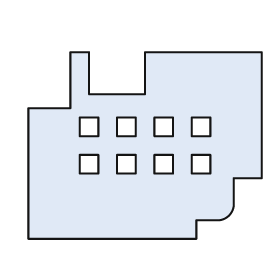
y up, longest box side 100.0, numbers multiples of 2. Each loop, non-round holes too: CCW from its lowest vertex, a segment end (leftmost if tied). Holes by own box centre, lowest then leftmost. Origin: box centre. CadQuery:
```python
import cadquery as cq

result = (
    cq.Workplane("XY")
    .moveTo(-50.0, -40.0)
    .lineTo(22.0, -40.0)
    .lineTo(22.0, -32.0)
    .lineTo(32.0, -32.0)
    .threePointArc((36.0, -30.0), (38.0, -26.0))
    .lineTo(38.0, -14.0)
    .lineTo(50.0, -14.0)
    .lineTo(50.0, 40.0)
    .lineTo(0.0, 40.0)
    .lineTo(0.0, 22.0)
    .lineTo(-24.0, 22.0)
    .lineTo(-24.0, 40.0)
    .lineTo(-32.0, 40.0)
    .lineTo(-32.0, 16.0)
    .lineTo(-50.0, 16.0)
    .close()
    .moveTo(-28.0, -12.0)
    .lineTo(-20.0, -12.0)
    .lineTo(-20.0, -4.0)
    .lineTo(-28.0, -4.0)
    .close()
    .moveTo(-12.0, -12.0)
    .lineTo(-4.0, -12.0)
    .lineTo(-4.0, -4.0)
    .lineTo(-12.0, -4.0)
    .close()
    .moveTo(4.0, -12.0)
    .lineTo(12.0, -12.0)
    .lineTo(12.0, -4.0)
    .lineTo(4.0, -4.0)
    .close()
    .moveTo(20.0, -12.0)
    .lineTo(28.0, -12.0)
    .lineTo(28.0, -4.0)
    .lineTo(20.0, -4.0)
    .close()
    .moveTo(-28.0, 4.0)
    .lineTo(-20.0, 4.0)
    .lineTo(-20.0, 12.0)
    .lineTo(-28.0, 12.0)
    .close()
    .moveTo(-12.0, 4.0)
    .lineTo(-4.0, 4.0)
    .lineTo(-4.0, 12.0)
    .lineTo(-12.0, 12.0)
    .close()
    .moveTo(4.0, 4.0)
    .lineTo(12.0, 4.0)
    .lineTo(12.0, 12.0)
    .lineTo(4.0, 12.0)
    .close()
    .moveTo(20.0, 4.0)
    .lineTo(28.0, 4.0)
    .lineTo(28.0, 12.0)
    .lineTo(20.0, 12.0)
    .close()
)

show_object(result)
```